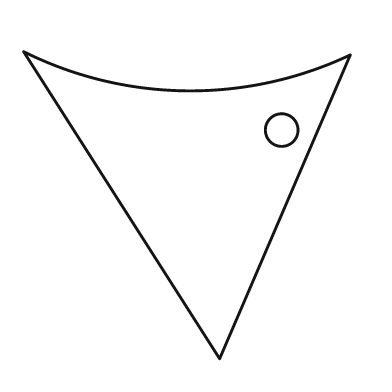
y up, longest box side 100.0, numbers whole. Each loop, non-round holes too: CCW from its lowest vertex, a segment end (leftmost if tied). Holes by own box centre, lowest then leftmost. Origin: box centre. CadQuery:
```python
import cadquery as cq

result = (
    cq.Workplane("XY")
    .moveTo(10.0, -47.0)
    .lineTo(50.0, 46.0)
    .threePointArc((0.0, 35.0), (-50.0, 47.0))
    .close()
    .moveTo(29.0, 23.0)
    .circle(5.0)
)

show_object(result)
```